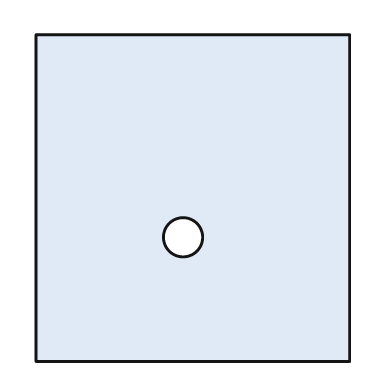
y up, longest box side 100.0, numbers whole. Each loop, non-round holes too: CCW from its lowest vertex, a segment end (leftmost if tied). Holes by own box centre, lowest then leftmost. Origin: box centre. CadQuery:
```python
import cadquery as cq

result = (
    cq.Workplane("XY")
    .moveTo(-48.0, -50.0)
    .lineTo(48.0, -50.0)
    .lineTo(48.0, 50.0)
    .lineTo(-48.0, 50.0)
    .close()
    .moveTo(-3.0, -12.0)
    .circle(6.0)
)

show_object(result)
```